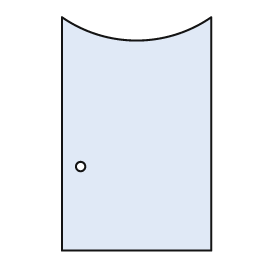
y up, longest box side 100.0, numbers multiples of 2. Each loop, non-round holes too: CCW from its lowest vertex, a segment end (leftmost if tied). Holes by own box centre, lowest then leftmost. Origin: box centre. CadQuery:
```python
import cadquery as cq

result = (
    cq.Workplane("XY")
    .moveTo(-32.0, -50.0)
    .lineTo(32.0, -50.0)
    .lineTo(32.0, 50.0)
    .threePointArc((0.0, 40.0), (-32.0, 50.0))
    .close()
    .moveTo(-24.0, -14.0)
    .circle(2.0)
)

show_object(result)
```